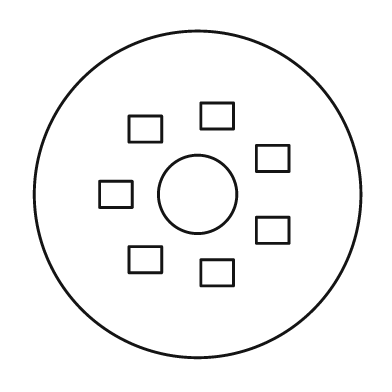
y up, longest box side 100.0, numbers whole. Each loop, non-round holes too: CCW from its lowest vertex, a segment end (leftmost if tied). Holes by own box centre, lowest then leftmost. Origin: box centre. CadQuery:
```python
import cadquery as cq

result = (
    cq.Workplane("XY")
    .moveTo(0.0, 0.0)
    .circle(50.0)
    .moveTo(1.0, -28.0)
    .lineTo(11.0, -28.0)
    .lineTo(11.0, -20.0)
    .lineTo(1.0, -20.0)
    .close()
    .moveTo(-21.0, -24.0)
    .lineTo(-11.0, -24.0)
    .lineTo(-11.0, -16.0)
    .lineTo(-21.0, -16.0)
    .close()
    .moveTo(18.0, -15.0)
    .lineTo(28.0, -15.0)
    .lineTo(28.0, -7.0)
    .lineTo(18.0, -7.0)
    .close()
    .moveTo(-30.0, -4.0)
    .lineTo(-20.0, -4.0)
    .lineTo(-20.0, 4.0)
    .lineTo(-30.0, 4.0)
    .close()
    .moveTo(0.0, 0.0)
    .circle(12.0)
    .moveTo(18.0, 7.0)
    .lineTo(28.0, 7.0)
    .lineTo(28.0, 15.0)
    .lineTo(18.0, 15.0)
    .close()
    .moveTo(-21.0, 16.0)
    .lineTo(-11.0, 16.0)
    .lineTo(-11.0, 24.0)
    .lineTo(-21.0, 24.0)
    .close()
    .moveTo(1.0, 20.0)
    .lineTo(11.0, 20.0)
    .lineTo(11.0, 28.0)
    .lineTo(1.0, 28.0)
    .close()
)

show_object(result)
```